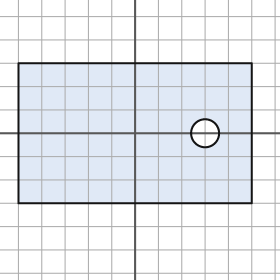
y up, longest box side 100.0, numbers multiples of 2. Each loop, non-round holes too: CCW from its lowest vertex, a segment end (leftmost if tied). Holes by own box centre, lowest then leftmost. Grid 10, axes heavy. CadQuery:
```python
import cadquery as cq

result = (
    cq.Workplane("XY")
    .moveTo(-50.0, -30.0)
    .lineTo(50.0, -30.0)
    .lineTo(50.0, 30.0)
    .lineTo(-50.0, 30.0)
    .close()
    .moveTo(30.0, 0.0)
    .circle(6.0)
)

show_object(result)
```